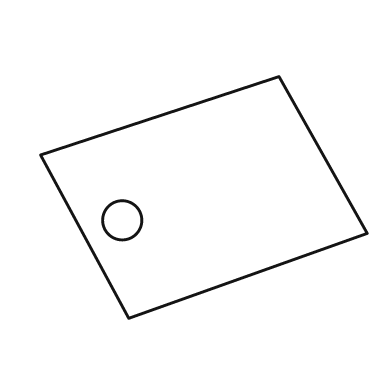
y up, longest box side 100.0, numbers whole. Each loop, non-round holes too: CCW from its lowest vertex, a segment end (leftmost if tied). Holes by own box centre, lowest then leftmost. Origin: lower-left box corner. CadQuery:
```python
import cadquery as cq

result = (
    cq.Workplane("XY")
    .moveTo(27.0, 0.0)
    .lineTo(100.0, 26.0)
    .lineTo(73.0, 74.0)
    .lineTo(0.0, 50.0)
    .close()
    .moveTo(25.0, 30.0)
    .circle(6.0)
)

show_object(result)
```